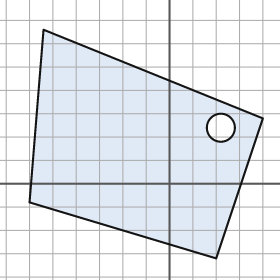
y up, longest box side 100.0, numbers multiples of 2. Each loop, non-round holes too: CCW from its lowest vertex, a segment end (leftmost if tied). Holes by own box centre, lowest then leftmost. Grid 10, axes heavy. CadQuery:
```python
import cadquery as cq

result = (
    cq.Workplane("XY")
    .moveTo(20.0, -32.0)
    .lineTo(40.0, 28.0)
    .lineTo(-54.0, 66.0)
    .lineTo(-60.0, -8.0)
    .close()
    .moveTo(22.0, 24.0)
    .circle(6.0)
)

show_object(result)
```